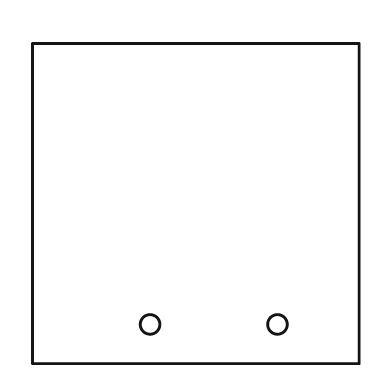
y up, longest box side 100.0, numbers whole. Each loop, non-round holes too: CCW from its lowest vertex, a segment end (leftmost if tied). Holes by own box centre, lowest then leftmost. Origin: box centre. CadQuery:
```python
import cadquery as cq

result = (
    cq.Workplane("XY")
    .moveTo(-50.0, -49.0)
    .lineTo(50.0, -49.0)
    .lineTo(50.0, 49.0)
    .lineTo(-50.0, 49.0)
    .close()
    .moveTo(-14.0, -37.0)
    .circle(3.0)
    .moveTo(25.0, -37.0)
    .circle(3.0)
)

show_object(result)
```